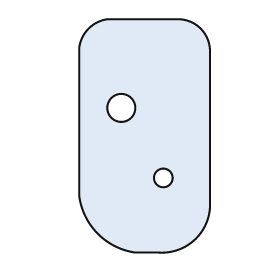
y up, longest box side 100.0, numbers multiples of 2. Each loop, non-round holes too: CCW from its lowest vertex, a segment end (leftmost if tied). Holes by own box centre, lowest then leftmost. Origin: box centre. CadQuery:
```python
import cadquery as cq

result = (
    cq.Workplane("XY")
    .moveTo(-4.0, -50.0)
    .lineTo(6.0, -50.0)
    .threePointArc((22.0, -44.0), (28.0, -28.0))
    .lineTo(28.0, 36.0)
    .threePointArc((24.0, 46.0), (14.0, 50.0))
    .lineTo(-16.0, 50.0)
    .threePointArc((-24.0, 46.0), (-28.0, 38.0))
    .lineTo(-28.0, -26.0)
    .threePointArc((-20.0, -42.0), (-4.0, -50.0))
    .close()
    .moveTo(8.0, -18.0)
    .circle(4.0)
    .moveTo(-10.0, 12.0)
    .circle(6.0)
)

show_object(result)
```